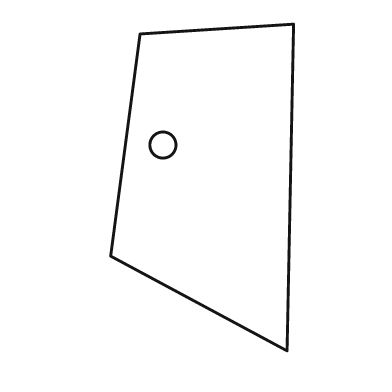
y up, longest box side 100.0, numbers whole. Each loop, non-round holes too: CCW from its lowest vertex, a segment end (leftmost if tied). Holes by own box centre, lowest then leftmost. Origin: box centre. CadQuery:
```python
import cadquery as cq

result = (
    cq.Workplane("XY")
    .moveTo(26.0, -50.0)
    .lineTo(28.0, 50.0)
    .lineTo(-19.0, 47.0)
    .lineTo(-28.0, -21.0)
    .close()
    .moveTo(-12.0, 13.0)
    .circle(4.0)
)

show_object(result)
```